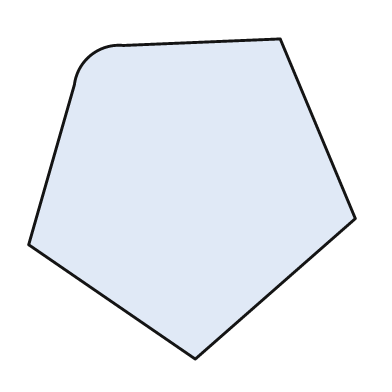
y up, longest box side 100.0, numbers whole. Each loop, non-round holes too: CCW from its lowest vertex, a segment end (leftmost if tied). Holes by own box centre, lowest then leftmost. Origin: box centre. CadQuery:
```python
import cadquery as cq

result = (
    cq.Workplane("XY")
    .moveTo(1.0, -49.0)
    .lineTo(50.0, -6.0)
    .lineTo(27.0, 49.0)
    .lineTo(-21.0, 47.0)
    .threePointArc((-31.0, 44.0), (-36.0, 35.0))
    .lineTo(-50.0, -14.0)
    .close()
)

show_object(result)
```